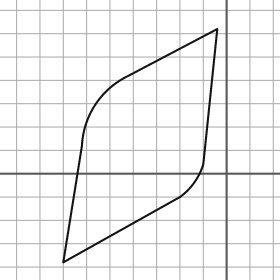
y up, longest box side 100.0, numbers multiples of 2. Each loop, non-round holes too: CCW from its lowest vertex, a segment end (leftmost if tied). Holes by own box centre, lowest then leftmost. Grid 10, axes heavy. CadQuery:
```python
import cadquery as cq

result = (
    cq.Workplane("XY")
    .moveTo(-70.0, -38.0)
    .lineTo(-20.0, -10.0)
    .threePointArc((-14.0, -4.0), (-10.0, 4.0))
    .lineTo(-4.0, 62.0)
    .lineTo(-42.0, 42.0)
    .threePointArc((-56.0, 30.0), (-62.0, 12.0))
    .close()
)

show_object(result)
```